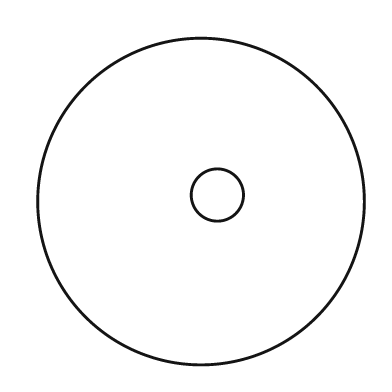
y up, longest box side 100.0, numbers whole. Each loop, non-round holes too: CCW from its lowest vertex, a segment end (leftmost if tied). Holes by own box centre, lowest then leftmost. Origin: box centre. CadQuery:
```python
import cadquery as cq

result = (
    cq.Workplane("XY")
    .moveTo(0.0, 0.0)
    .circle(50.0)
    .moveTo(5.0, 2.0)
    .circle(8.0)
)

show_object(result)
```